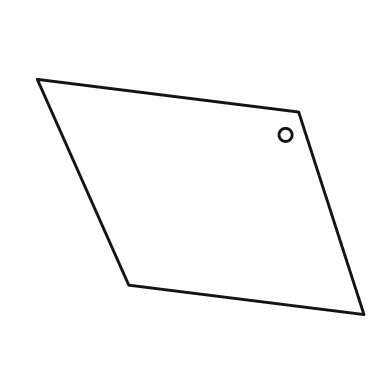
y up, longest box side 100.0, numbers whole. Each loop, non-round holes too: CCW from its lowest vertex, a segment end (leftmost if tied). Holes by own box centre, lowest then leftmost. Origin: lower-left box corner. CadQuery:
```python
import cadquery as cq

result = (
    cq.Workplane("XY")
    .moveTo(100.0, 0.0)
    .lineTo(80.0, 62.0)
    .lineTo(0.0, 72.0)
    .lineTo(28.0, 9.0)
    .close()
    .moveTo(76.0, 55.0)
    .circle(2.0)
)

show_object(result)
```